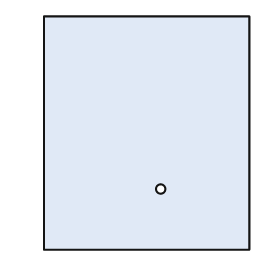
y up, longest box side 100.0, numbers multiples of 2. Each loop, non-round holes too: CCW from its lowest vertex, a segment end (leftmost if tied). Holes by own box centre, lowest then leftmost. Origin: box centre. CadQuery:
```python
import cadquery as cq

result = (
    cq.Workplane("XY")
    .moveTo(-44.0, -50.0)
    .lineTo(44.0, -50.0)
    .lineTo(44.0, 50.0)
    .lineTo(-44.0, 50.0)
    .close()
    .moveTo(6.0, -24.0)
    .circle(2.0)
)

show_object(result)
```